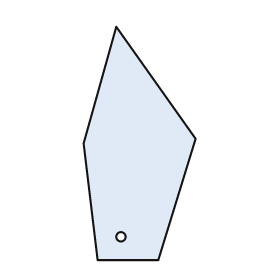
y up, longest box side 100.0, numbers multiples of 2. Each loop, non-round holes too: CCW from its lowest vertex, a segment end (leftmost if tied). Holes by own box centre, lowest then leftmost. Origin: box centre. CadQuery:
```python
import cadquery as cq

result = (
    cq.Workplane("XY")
    .moveTo(-18.0, -50.0)
    .lineTo(8.0, -50.0)
    .lineTo(24.0, 2.0)
    .lineTo(-10.0, 50.0)
    .lineTo(-24.0, 0.0)
    .close()
    .moveTo(-8.0, -40.0)
    .circle(2.0)
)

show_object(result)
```